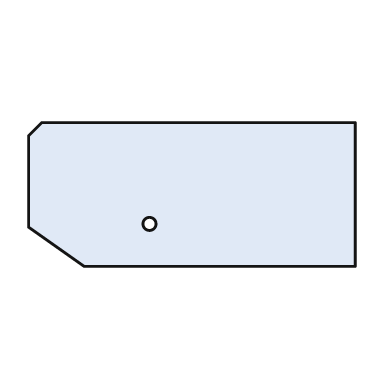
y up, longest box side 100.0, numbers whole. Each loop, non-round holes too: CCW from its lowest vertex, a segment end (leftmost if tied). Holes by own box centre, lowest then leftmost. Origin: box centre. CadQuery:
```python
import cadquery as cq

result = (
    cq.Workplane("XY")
    .moveTo(-33.0, -22.0)
    .lineTo(50.0, -22.0)
    .lineTo(50.0, 22.0)
    .lineTo(-46.0, 22.0)
    .lineTo(-50.0, 18.0)
    .lineTo(-50.0, -10.0)
    .close()
    .moveTo(-13.0, -9.0)
    .circle(2.0)
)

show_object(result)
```